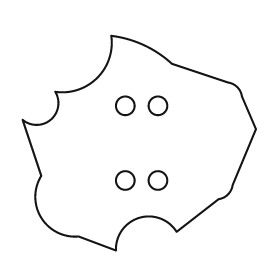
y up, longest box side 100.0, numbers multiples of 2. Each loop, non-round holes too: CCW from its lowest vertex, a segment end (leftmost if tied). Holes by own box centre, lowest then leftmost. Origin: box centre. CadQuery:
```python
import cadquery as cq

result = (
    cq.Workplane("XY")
    .moveTo(-10.0, -46.0)
    .threePointArc((0.0, -32.0), (16.0, -38.0))
    .lineTo(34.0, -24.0)
    .threePointArc((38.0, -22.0), (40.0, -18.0))
    .lineTo(50.0, 6.0)
    .lineTo(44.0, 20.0)
    .threePointArc((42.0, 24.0), (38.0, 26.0))
    .lineTo(14.0, 34.0)
    .threePointArc((2.0, 42.0), (-12.0, 46.0))
    .threePointArc((-18.0, 28.0), (-36.0, 22.0))
    .threePointArc((-38.0, 10.0), (-50.0, 10.0))
    .lineTo(-42.0, -14.0)
    .threePointArc((-42.0, -32.0), (-26.0, -40.0))
    .close()
    .moveTo(-6.0, -16.0)
    .circle(4.0)
    .moveTo(8.0, -16.0)
    .circle(4.0)
    .moveTo(-6.0, 16.0)
    .circle(4.0)
    .moveTo(8.0, 16.0)
    .circle(4.0)
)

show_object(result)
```